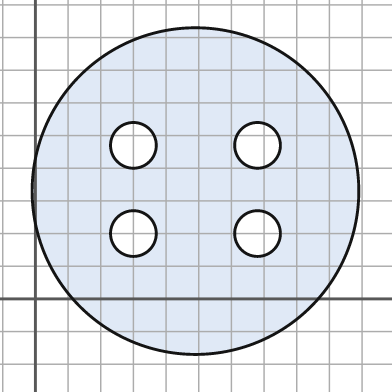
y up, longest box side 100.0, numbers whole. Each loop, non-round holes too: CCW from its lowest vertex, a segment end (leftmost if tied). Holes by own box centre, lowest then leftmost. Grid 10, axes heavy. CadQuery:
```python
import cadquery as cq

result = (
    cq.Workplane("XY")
    .moveTo(49.0, 33.0)
    .circle(50.0)
    .moveTo(30.0, 20.0)
    .circle(7.0)
    .moveTo(68.0, 20.0)
    .circle(7.0)
    .moveTo(30.0, 47.0)
    .circle(7.0)
    .moveTo(68.0, 47.0)
    .circle(7.0)
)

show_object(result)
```